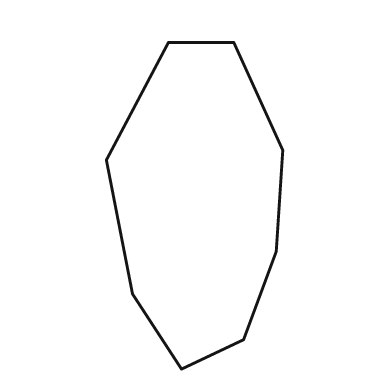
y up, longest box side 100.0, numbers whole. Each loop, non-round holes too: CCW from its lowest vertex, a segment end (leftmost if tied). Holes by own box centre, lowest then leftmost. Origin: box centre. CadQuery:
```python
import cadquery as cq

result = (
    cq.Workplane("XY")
    .moveTo(-4.0, -50.0)
    .lineTo(15.0, -41.0)
    .lineTo(25.0, -14.0)
    .lineTo(27.0, 17.0)
    .lineTo(12.0, 50.0)
    .lineTo(-8.0, 50.0)
    .lineTo(-27.0, 14.0)
    .lineTo(-19.0, -27.0)
    .close()
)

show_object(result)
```